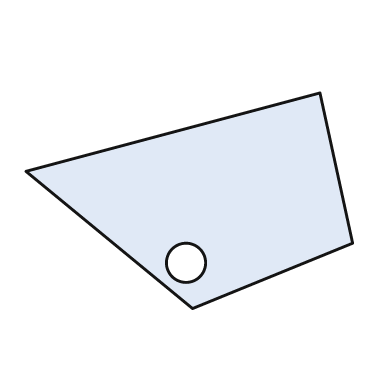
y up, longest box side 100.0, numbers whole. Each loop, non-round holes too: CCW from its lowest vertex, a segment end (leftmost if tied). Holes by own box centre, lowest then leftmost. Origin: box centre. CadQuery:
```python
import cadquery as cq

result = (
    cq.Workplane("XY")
    .moveTo(1.0, -33.0)
    .lineTo(50.0, -13.0)
    .lineTo(40.0, 33.0)
    .lineTo(-50.0, 9.0)
    .close()
    .moveTo(-1.0, -19.0)
    .circle(6.0)
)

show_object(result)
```